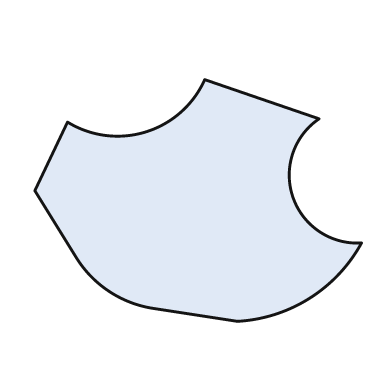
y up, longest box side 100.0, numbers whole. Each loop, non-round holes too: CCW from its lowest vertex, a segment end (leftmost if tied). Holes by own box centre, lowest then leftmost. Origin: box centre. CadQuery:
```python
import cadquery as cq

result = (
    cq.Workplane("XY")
    .moveTo(12.0, -37.0)
    .threePointArc((34.0, -30.0), (50.0, -13.0))
    .threePointArc((29.0, 1.0), (37.0, 25.0))
    .lineTo(2.0, 37.0)
    .threePointArc((-16.0, 21.0), (-40.0, 24.0))
    .lineTo(-50.0, 3.0)
    .lineTo(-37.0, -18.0)
    .threePointArc((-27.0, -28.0), (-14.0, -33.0))
    .close()
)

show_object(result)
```